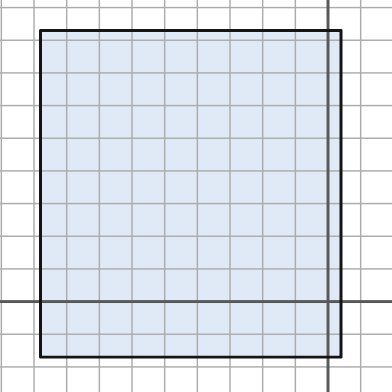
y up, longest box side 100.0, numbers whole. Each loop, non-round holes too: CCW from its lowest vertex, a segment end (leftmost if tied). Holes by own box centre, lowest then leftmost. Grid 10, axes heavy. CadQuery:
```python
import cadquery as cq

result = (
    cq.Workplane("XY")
    .moveTo(-88.0, -17.0)
    .lineTo(4.0, -17.0)
    .lineTo(4.0, 83.0)
    .lineTo(-88.0, 83.0)
    .close()
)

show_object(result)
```